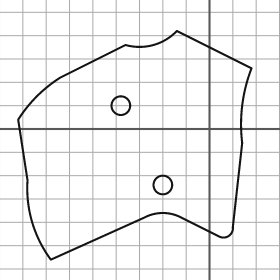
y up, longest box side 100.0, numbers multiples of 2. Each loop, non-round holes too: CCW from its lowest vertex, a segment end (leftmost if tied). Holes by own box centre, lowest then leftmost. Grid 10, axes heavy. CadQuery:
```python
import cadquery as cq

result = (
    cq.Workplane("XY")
    .moveTo(-68.0, -56.0)
    .lineTo(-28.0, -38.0)
    .threePointArc((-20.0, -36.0), (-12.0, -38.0))
    .lineTo(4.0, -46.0)
    .threePointArc((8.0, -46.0), (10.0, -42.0))
    .lineTo(14.0, -6.0)
    .threePointArc((14.0, 10.0), (18.0, 26.0))
    .lineTo(-14.0, 42.0)
    .threePointArc((-24.0, 36.0), (-36.0, 36.0))
    .lineTo(-64.0, 22.0)
    .threePointArc((-74.0, 14.0), (-82.0, 4.0))
    .lineTo(-78.0, -22.0)
    .threePointArc((-76.0, -40.0), (-68.0, -56.0))
    .close()
    .moveTo(-20.0, -24.0)
    .circle(4.0)
    .moveTo(-38.0, 10.0)
    .circle(4.0)
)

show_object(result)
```